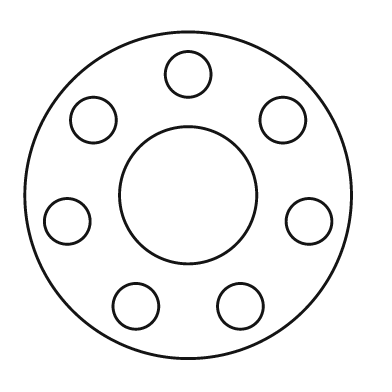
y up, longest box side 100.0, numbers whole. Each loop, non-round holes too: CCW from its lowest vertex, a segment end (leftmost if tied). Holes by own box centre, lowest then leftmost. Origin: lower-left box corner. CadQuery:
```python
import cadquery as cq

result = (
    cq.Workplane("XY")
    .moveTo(50.0, 50.0)
    .circle(50.0)
    .moveTo(34.0, 16.0)
    .circle(7.0)
    .moveTo(66.0, 16.0)
    .circle(7.0)
    .moveTo(13.0, 42.0)
    .circle(7.0)
    .moveTo(87.0, 42.0)
    .circle(7.0)
    .moveTo(50.0, 50.0)
    .circle(21.0)
    .moveTo(21.0, 73.0)
    .circle(7.0)
    .moveTo(79.0, 73.0)
    .circle(7.0)
    .moveTo(50.0, 87.0)
    .circle(7.0)
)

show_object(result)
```